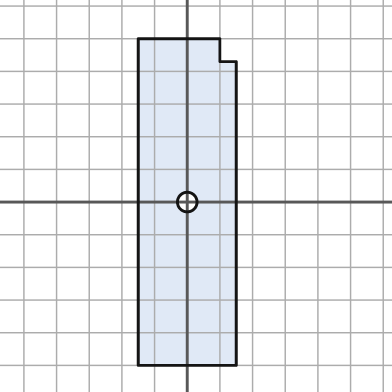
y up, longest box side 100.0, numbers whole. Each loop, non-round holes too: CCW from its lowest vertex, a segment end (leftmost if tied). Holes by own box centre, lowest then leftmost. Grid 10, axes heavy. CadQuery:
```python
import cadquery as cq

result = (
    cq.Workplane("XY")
    .moveTo(-15.0, -50.0)
    .lineTo(15.0, -50.0)
    .lineTo(15.0, 43.0)
    .lineTo(10.0, 43.0)
    .lineTo(10.0, 50.0)
    .lineTo(-15.0, 50.0)
    .close()
    .moveTo(0.0, 0.0)
    .circle(3.0)
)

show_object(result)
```